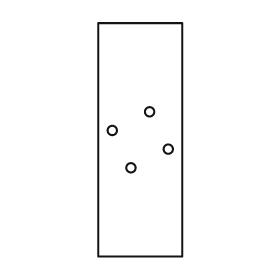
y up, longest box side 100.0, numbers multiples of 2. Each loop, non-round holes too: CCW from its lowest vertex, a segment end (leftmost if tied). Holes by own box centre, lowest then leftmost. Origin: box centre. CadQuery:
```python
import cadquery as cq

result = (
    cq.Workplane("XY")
    .moveTo(-18.0, -50.0)
    .lineTo(18.0, -50.0)
    .lineTo(18.0, 50.0)
    .lineTo(-18.0, 50.0)
    .close()
    .moveTo(-4.0, -12.0)
    .circle(2.0)
    .moveTo(12.0, -4.0)
    .circle(2.0)
    .moveTo(-12.0, 4.0)
    .circle(2.0)
    .moveTo(4.0, 12.0)
    .circle(2.0)
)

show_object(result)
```